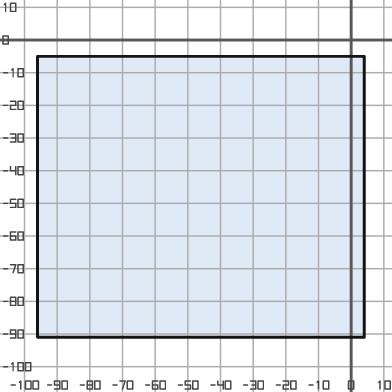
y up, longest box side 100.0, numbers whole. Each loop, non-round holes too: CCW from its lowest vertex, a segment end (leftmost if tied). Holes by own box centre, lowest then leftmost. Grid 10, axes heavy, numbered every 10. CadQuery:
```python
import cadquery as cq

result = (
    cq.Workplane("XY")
    .moveTo(-96.0, -91.0)
    .lineTo(4.0, -91.0)
    .lineTo(4.0, -5.0)
    .lineTo(-96.0, -5.0)
    .close()
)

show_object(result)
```